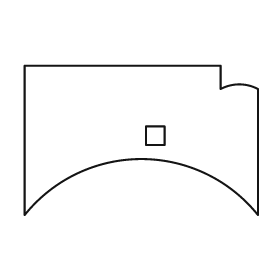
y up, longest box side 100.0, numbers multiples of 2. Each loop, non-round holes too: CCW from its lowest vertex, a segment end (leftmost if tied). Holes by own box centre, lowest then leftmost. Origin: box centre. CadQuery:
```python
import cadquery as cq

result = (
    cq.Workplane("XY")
    .moveTo(-50.0, -32.0)
    .threePointArc((0.0, -8.0), (50.0, -32.0))
    .lineTo(50.0, 22.0)
    .threePointArc((42.0, 24.0), (34.0, 22.0))
    .lineTo(34.0, 32.0)
    .lineTo(-50.0, 32.0)
    .close()
    .moveTo(2.0, -2.0)
    .lineTo(10.0, -2.0)
    .lineTo(10.0, 6.0)
    .lineTo(2.0, 6.0)
    .close()
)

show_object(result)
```